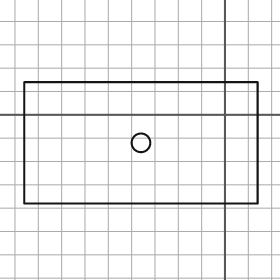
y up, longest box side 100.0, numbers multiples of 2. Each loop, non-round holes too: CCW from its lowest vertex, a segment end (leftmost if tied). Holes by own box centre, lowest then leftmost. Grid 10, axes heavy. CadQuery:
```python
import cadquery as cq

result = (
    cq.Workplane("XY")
    .moveTo(-86.0, -38.0)
    .lineTo(14.0, -38.0)
    .lineTo(14.0, 14.0)
    .lineTo(-86.0, 14.0)
    .close()
    .moveTo(-36.0, -12.0)
    .circle(4.0)
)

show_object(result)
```